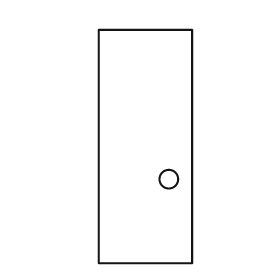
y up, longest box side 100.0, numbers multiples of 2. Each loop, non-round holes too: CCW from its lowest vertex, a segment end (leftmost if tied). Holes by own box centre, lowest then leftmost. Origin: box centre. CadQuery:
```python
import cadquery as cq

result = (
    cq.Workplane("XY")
    .moveTo(-20.0, -50.0)
    .lineTo(20.0, -50.0)
    .lineTo(20.0, 50.0)
    .lineTo(-20.0, 50.0)
    .close()
    .moveTo(10.0, -14.0)
    .circle(4.0)
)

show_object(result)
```